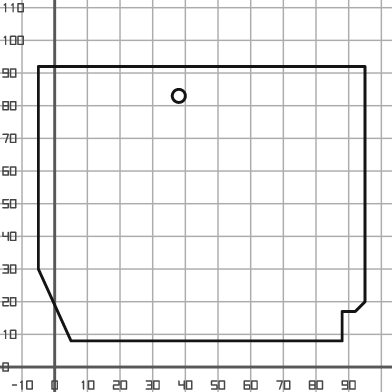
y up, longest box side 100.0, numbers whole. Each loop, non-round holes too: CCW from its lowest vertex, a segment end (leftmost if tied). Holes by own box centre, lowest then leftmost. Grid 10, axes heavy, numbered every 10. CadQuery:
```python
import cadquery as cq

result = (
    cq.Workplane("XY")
    .moveTo(5.0, 8.0)
    .lineTo(88.0, 8.0)
    .lineTo(88.0, 17.0)
    .lineTo(92.0, 17.0)
    .lineTo(95.0, 20.0)
    .lineTo(95.0, 92.0)
    .lineTo(-5.0, 92.0)
    .lineTo(-5.0, 30.0)
    .close()
    .moveTo(38.0, 83.0)
    .circle(2.0)
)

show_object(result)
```